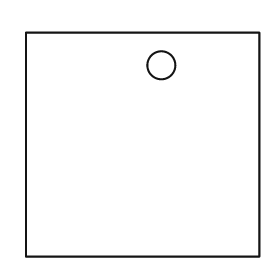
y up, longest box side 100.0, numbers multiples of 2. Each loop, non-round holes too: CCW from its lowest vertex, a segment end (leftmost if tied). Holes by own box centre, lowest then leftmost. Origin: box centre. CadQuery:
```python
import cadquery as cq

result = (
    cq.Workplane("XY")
    .moveTo(-50.0, -48.0)
    .lineTo(50.0, -48.0)
    .lineTo(50.0, 48.0)
    .lineTo(-50.0, 48.0)
    .close()
    .moveTo(8.0, 34.0)
    .circle(6.0)
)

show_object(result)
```